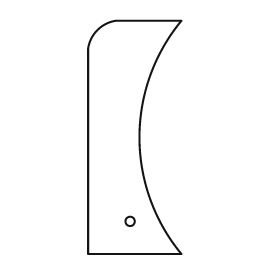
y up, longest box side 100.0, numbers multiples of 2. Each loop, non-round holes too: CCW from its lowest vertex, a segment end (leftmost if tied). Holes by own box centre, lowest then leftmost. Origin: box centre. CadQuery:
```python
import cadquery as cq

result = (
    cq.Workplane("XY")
    .moveTo(-20.0, -50.0)
    .lineTo(20.0, -50.0)
    .threePointArc((2.0, 0.0), (20.0, 50.0))
    .lineTo(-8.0, 50.0)
    .threePointArc((-16.0, 46.0), (-20.0, 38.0))
    .close()
    .moveTo(-2.0, -36.0)
    .circle(2.0)
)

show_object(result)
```